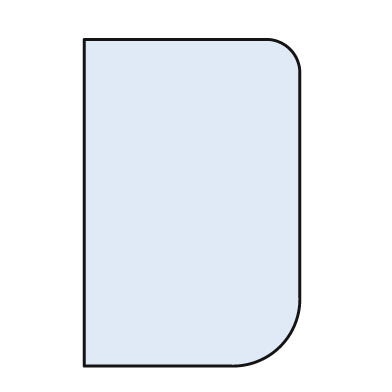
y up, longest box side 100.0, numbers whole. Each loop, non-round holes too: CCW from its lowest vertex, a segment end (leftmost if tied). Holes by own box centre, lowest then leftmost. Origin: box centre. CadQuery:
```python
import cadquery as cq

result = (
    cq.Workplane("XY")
    .moveTo(-33.0, -50.0)
    .lineTo(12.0, -50.0)
    .threePointArc((27.0, -44.0), (33.0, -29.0))
    .lineTo(33.0, 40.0)
    .threePointArc((30.0, 47.0), (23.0, 50.0))
    .lineTo(-33.0, 50.0)
    .close()
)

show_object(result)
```